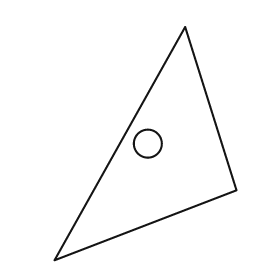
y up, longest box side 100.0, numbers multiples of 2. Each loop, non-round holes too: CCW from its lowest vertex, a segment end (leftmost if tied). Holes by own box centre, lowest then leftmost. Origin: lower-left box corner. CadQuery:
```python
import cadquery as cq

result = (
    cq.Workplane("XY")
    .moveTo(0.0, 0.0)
    .lineTo(78.0, 30.0)
    .lineTo(56.0, 100.0)
    .close()
    .moveTo(40.0, 50.0)
    .circle(6.0)
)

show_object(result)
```